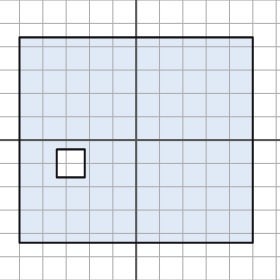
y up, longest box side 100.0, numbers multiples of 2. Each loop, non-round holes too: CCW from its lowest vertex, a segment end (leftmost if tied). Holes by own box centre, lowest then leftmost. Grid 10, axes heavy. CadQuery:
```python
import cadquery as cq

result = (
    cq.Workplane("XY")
    .moveTo(-50.0, -44.0)
    .lineTo(50.0, -44.0)
    .lineTo(50.0, 44.0)
    .lineTo(-50.0, 44.0)
    .close()
    .moveTo(-34.0, -16.0)
    .lineTo(-22.0, -16.0)
    .lineTo(-22.0, -4.0)
    .lineTo(-34.0, -4.0)
    .close()
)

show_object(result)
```